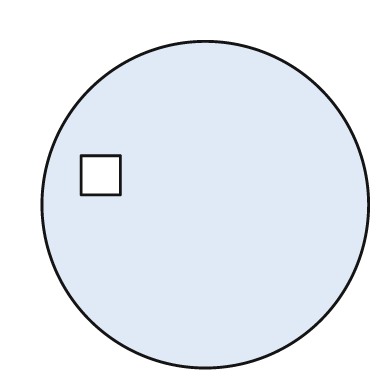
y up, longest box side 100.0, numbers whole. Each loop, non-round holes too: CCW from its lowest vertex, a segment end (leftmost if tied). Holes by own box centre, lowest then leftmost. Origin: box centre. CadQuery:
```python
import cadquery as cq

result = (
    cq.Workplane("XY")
    .moveTo(0.0, 0.0)
    .circle(50.0)
    .moveTo(-38.0, 3.0)
    .lineTo(-26.0, 3.0)
    .lineTo(-26.0, 15.0)
    .lineTo(-38.0, 15.0)
    .close()
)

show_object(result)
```